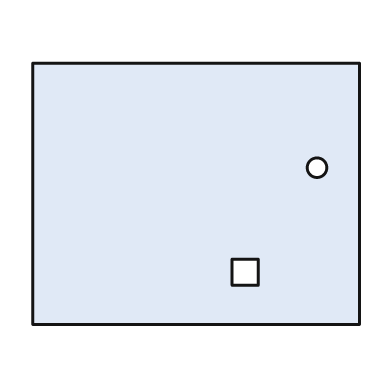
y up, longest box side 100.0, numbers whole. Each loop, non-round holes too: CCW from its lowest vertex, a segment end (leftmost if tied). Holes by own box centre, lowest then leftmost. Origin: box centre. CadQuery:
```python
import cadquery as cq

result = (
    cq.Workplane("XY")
    .moveTo(-50.0, -40.0)
    .lineTo(50.0, -40.0)
    .lineTo(50.0, 40.0)
    .lineTo(-50.0, 40.0)
    .close()
    .moveTo(11.0, -28.0)
    .lineTo(19.0, -28.0)
    .lineTo(19.0, -20.0)
    .lineTo(11.0, -20.0)
    .close()
    .moveTo(37.0, 8.0)
    .circle(3.0)
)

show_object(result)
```